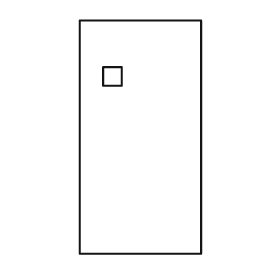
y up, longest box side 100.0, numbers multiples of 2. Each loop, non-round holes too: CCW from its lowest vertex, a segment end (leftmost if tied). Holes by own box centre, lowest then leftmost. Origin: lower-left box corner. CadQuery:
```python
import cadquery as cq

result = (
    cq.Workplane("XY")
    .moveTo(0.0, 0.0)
    .lineTo(52.0, 0.0)
    .lineTo(52.0, 100.0)
    .lineTo(0.0, 100.0)
    .close()
    .moveTo(10.0, 72.0)
    .lineTo(18.0, 72.0)
    .lineTo(18.0, 80.0)
    .lineTo(10.0, 80.0)
    .close()
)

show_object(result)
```